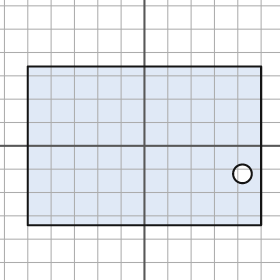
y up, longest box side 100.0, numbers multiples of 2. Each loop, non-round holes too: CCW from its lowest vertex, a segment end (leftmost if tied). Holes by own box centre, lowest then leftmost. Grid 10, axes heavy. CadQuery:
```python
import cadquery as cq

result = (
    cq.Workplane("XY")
    .moveTo(-50.0, -34.0)
    .lineTo(50.0, -34.0)
    .lineTo(50.0, 34.0)
    .lineTo(-50.0, 34.0)
    .close()
    .moveTo(42.0, -12.0)
    .circle(4.0)
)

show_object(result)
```